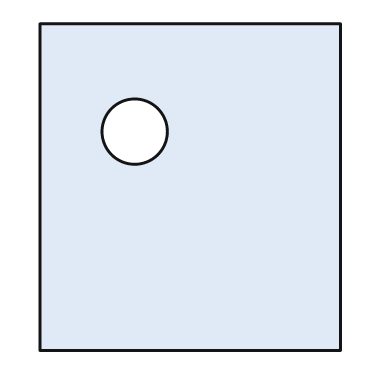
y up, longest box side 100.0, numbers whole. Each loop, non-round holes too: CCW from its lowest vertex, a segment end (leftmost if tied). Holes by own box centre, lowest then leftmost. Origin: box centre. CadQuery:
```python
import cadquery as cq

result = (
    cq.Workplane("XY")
    .moveTo(-46.0, -50.0)
    .lineTo(46.0, -50.0)
    .lineTo(46.0, 50.0)
    .lineTo(-46.0, 50.0)
    .close()
    .moveTo(-17.0, 17.0)
    .circle(10.0)
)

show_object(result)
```